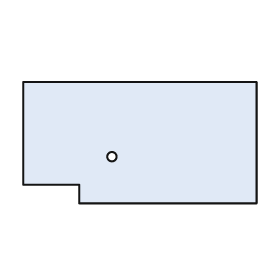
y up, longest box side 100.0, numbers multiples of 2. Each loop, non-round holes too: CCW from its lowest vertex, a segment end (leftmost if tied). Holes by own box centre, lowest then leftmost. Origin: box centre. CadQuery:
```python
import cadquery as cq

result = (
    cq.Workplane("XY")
    .moveTo(-26.0, -26.0)
    .lineTo(50.0, -26.0)
    .lineTo(50.0, 26.0)
    .lineTo(-50.0, 26.0)
    .lineTo(-50.0, -18.0)
    .lineTo(-26.0, -18.0)
    .close()
    .moveTo(-12.0, -6.0)
    .circle(2.0)
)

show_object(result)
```